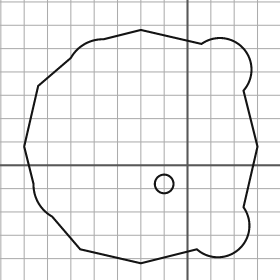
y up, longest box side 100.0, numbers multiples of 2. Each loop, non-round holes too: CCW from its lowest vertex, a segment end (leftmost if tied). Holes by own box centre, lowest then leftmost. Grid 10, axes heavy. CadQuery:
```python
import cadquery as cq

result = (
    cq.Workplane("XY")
    .moveTo(-20.0, -42.0)
    .lineTo(4.0, -36.0)
    .threePointArc((22.0, -36.0), (24.0, -18.0))
    .lineTo(30.0, 8.0)
    .lineTo(24.0, 32.0)
    .threePointArc((24.0, 50.0), (6.0, 52.0))
    .lineTo(-20.0, 58.0)
    .lineTo(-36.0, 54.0)
    .threePointArc((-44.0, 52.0), (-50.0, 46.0))
    .lineTo(-64.0, 34.0)
    .lineTo(-70.0, 8.0)
    .lineTo(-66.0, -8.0)
    .threePointArc((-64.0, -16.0), (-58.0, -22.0))
    .lineTo(-46.0, -36.0)
    .close()
    .moveTo(-10.0, -8.0)
    .circle(4.0)
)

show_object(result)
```